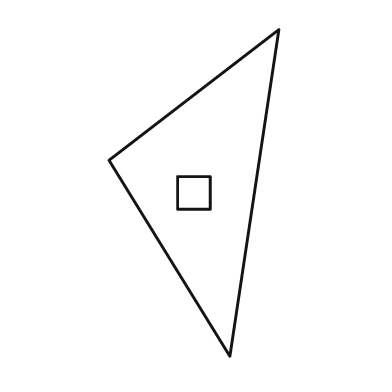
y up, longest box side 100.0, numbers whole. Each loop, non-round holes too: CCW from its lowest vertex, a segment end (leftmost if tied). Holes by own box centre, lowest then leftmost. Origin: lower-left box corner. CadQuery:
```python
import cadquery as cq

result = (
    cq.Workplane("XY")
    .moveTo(37.0, 0.0)
    .lineTo(52.0, 100.0)
    .lineTo(0.0, 60.0)
    .close()
    .moveTo(21.0, 45.0)
    .lineTo(31.0, 45.0)
    .lineTo(31.0, 55.0)
    .lineTo(21.0, 55.0)
    .close()
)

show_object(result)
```